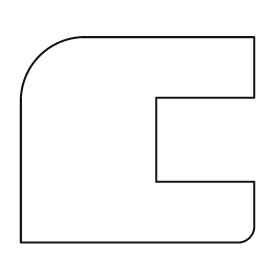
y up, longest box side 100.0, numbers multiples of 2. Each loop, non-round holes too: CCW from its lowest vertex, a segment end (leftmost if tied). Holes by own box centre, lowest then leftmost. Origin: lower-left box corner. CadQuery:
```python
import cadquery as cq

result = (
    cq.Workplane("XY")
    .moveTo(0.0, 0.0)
    .lineTo(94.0, 0.0)
    .threePointArc((98.0, 2.0), (100.0, 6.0))
    .lineTo(100.0, 26.0)
    .lineTo(58.0, 26.0)
    .lineTo(58.0, 62.0)
    .lineTo(100.0, 62.0)
    .lineTo(100.0, 88.0)
    .lineTo(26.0, 88.0)
    .threePointArc((8.0, 80.0), (0.0, 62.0))
    .close()
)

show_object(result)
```